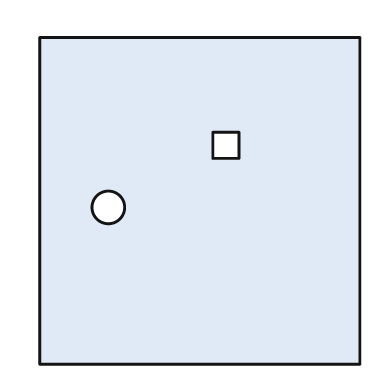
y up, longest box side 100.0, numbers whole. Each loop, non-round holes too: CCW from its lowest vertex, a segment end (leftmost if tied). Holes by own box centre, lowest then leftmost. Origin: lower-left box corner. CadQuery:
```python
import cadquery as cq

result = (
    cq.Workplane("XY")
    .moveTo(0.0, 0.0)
    .lineTo(98.0, 0.0)
    .lineTo(98.0, 100.0)
    .lineTo(0.0, 100.0)
    .close()
    .moveTo(21.0, 48.0)
    .circle(5.0)
    .moveTo(53.0, 63.0)
    .lineTo(61.0, 63.0)
    .lineTo(61.0, 71.0)
    .lineTo(53.0, 71.0)
    .close()
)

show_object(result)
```